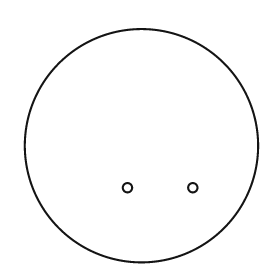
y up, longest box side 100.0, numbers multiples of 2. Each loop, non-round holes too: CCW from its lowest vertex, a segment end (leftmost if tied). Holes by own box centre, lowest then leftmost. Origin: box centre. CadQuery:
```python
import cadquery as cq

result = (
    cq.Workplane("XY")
    .moveTo(0.0, 0.0)
    .circle(50.0)
    .moveTo(-6.0, -18.0)
    .circle(2.0)
    .moveTo(22.0, -18.0)
    .circle(2.0)
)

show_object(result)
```